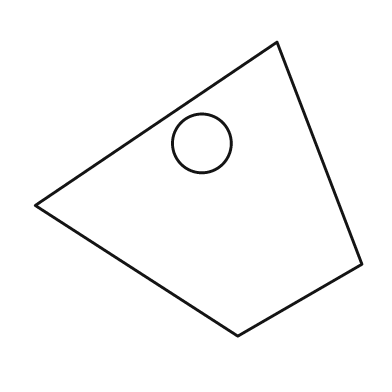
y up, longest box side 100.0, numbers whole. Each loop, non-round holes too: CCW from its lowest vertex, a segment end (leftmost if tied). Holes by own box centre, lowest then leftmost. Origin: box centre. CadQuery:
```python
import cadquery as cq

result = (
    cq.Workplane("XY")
    .moveTo(12.0, -45.0)
    .lineTo(50.0, -23.0)
    .lineTo(24.0, 45.0)
    .lineTo(-50.0, -5.0)
    .close()
    .moveTo(1.0, 14.0)
    .circle(9.0)
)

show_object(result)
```